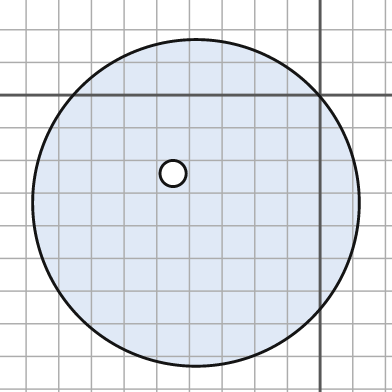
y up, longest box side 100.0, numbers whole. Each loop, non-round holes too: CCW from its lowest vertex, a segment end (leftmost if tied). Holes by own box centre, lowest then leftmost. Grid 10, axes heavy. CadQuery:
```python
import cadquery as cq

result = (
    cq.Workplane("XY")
    .moveTo(-38.0, -33.0)
    .circle(50.0)
    .moveTo(-45.0, -24.0)
    .circle(4.0)
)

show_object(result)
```